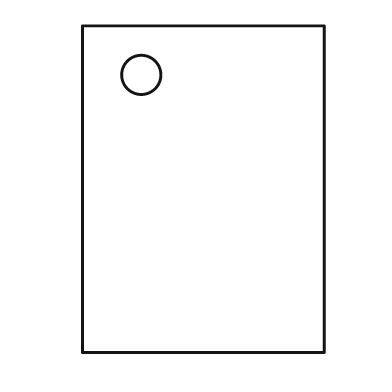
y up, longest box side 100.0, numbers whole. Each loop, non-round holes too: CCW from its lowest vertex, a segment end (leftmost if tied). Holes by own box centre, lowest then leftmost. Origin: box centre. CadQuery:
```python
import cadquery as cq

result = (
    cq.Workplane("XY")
    .moveTo(-37.0, -50.0)
    .lineTo(37.0, -50.0)
    .lineTo(37.0, 50.0)
    .lineTo(-37.0, 50.0)
    .close()
    .moveTo(-19.0, 35.0)
    .circle(6.0)
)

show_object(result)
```